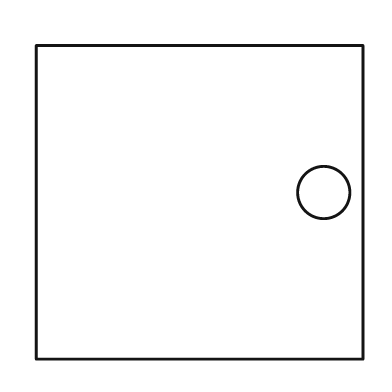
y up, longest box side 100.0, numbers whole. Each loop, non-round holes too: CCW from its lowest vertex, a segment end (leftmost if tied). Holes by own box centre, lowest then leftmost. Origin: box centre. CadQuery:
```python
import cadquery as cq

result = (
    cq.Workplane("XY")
    .moveTo(-50.0, -48.0)
    .lineTo(50.0, -48.0)
    .lineTo(50.0, 48.0)
    .lineTo(-50.0, 48.0)
    .close()
    .moveTo(38.0, 3.0)
    .circle(8.0)
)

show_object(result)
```